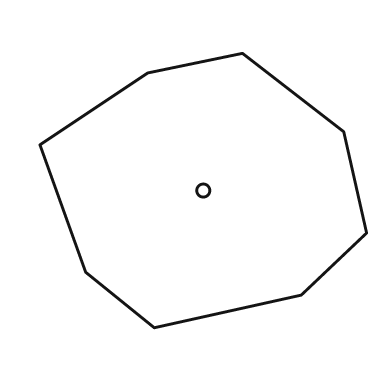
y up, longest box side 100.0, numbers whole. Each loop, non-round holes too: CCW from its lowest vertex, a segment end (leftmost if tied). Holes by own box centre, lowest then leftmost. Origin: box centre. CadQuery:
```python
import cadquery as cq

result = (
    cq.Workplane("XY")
    .moveTo(-15.0, -42.0)
    .lineTo(30.0, -32.0)
    .lineTo(50.0, -13.0)
    .lineTo(43.0, 18.0)
    .lineTo(12.0, 42.0)
    .lineTo(-17.0, 36.0)
    .lineTo(-50.0, 14.0)
    .lineTo(-36.0, -25.0)
    .close()
    .moveTo(0.0, 0.0)
    .circle(2.0)
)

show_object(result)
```